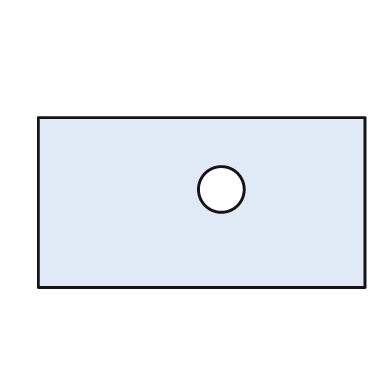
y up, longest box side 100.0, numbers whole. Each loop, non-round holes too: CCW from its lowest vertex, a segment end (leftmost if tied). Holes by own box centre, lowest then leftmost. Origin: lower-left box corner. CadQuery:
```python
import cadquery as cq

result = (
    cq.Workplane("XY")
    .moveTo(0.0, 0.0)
    .lineTo(100.0, 0.0)
    .lineTo(100.0, 52.0)
    .lineTo(0.0, 52.0)
    .close()
    .moveTo(56.0, 30.0)
    .circle(7.0)
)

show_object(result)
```